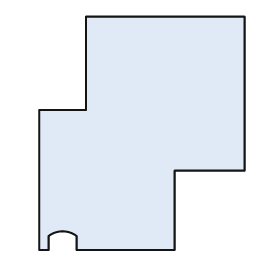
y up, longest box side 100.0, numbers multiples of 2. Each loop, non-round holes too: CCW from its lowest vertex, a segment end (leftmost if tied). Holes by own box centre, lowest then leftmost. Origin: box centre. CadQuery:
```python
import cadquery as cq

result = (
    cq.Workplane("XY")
    .moveTo(-44.0, -50.0)
    .lineTo(-40.0, -50.0)
    .lineTo(-40.0, -44.0)
    .threePointArc((-34.0, -42.0), (-28.0, -44.0))
    .lineTo(-28.0, -50.0)
    .lineTo(14.0, -50.0)
    .lineTo(14.0, -16.0)
    .lineTo(44.0, -16.0)
    .lineTo(44.0, 50.0)
    .lineTo(-24.0, 50.0)
    .lineTo(-24.0, 10.0)
    .lineTo(-44.0, 10.0)
    .close()
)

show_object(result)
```